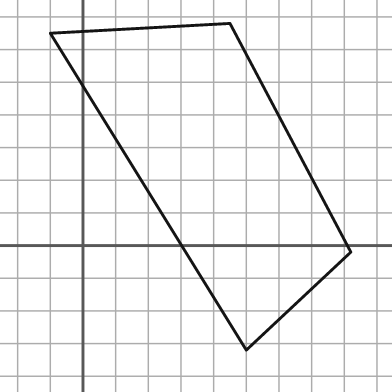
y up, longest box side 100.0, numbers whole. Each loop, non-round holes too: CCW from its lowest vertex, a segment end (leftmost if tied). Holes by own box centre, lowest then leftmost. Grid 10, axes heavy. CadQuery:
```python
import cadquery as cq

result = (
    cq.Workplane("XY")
    .moveTo(50.0, -32.0)
    .lineTo(82.0, -2.0)
    .lineTo(45.0, 68.0)
    .lineTo(-10.0, 65.0)
    .close()
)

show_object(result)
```